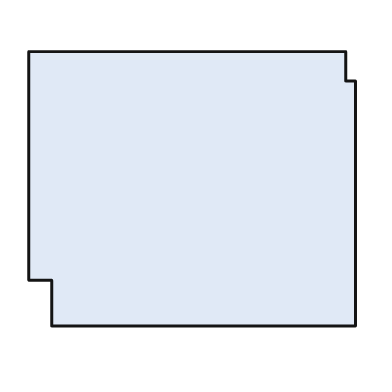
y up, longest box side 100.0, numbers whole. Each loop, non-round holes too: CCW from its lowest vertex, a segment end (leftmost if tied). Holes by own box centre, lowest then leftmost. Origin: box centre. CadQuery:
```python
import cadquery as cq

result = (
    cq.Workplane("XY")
    .moveTo(-43.0, -42.0)
    .lineTo(50.0, -42.0)
    .lineTo(50.0, 33.0)
    .lineTo(47.0, 33.0)
    .lineTo(47.0, 42.0)
    .lineTo(-50.0, 42.0)
    .lineTo(-50.0, -28.0)
    .lineTo(-43.0, -28.0)
    .close()
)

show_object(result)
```